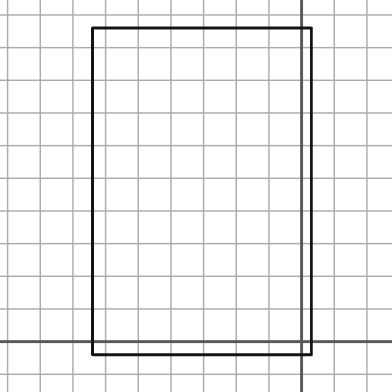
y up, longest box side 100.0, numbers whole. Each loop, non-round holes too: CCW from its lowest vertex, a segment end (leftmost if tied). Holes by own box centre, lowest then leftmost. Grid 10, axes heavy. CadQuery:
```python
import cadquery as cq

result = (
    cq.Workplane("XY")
    .moveTo(-64.0, -4.0)
    .lineTo(3.0, -4.0)
    .lineTo(3.0, 96.0)
    .lineTo(-64.0, 96.0)
    .close()
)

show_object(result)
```